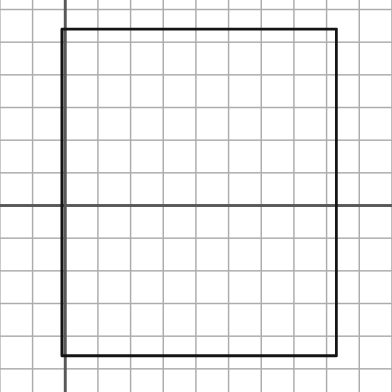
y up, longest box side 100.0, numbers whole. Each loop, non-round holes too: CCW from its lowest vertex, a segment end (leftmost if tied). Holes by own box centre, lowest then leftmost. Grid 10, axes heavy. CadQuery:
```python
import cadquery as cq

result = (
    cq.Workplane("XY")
    .moveTo(-1.0, -46.0)
    .lineTo(83.0, -46.0)
    .lineTo(83.0, 54.0)
    .lineTo(-1.0, 54.0)
    .close()
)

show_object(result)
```